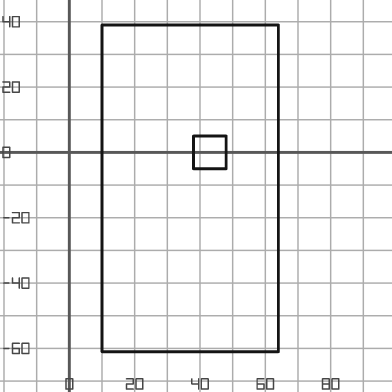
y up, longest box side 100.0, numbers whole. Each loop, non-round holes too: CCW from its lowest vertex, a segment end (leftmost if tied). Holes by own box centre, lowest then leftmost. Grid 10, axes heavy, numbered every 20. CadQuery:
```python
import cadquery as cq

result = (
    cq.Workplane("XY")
    .moveTo(10.0, -61.0)
    .lineTo(64.0, -61.0)
    .lineTo(64.0, 39.0)
    .lineTo(10.0, 39.0)
    .close()
    .moveTo(38.0, -5.0)
    .lineTo(48.0, -5.0)
    .lineTo(48.0, 5.0)
    .lineTo(38.0, 5.0)
    .close()
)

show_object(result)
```